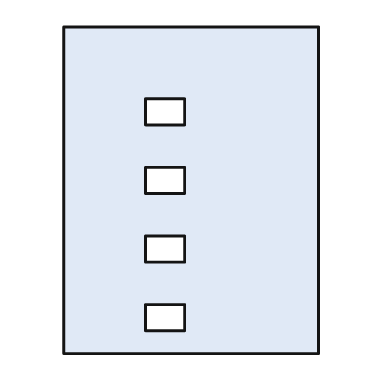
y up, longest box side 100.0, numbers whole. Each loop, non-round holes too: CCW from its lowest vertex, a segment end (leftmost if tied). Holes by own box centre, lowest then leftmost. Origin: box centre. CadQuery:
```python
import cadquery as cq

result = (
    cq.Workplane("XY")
    .moveTo(-39.0, -50.0)
    .lineTo(39.0, -50.0)
    .lineTo(39.0, 50.0)
    .lineTo(-39.0, 50.0)
    .close()
    .moveTo(-14.0, -43.0)
    .lineTo(-2.0, -43.0)
    .lineTo(-2.0, -35.0)
    .lineTo(-14.0, -35.0)
    .close()
    .moveTo(-14.0, -22.0)
    .lineTo(-2.0, -22.0)
    .lineTo(-2.0, -14.0)
    .lineTo(-14.0, -14.0)
    .close()
    .moveTo(-14.0, -1.0)
    .lineTo(-2.0, -1.0)
    .lineTo(-2.0, 7.0)
    .lineTo(-14.0, 7.0)
    .close()
    .moveTo(-14.0, 20.0)
    .lineTo(-2.0, 20.0)
    .lineTo(-2.0, 28.0)
    .lineTo(-14.0, 28.0)
    .close()
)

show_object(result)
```